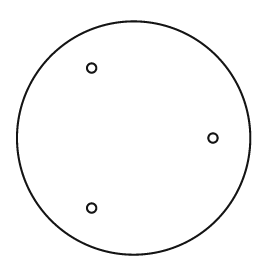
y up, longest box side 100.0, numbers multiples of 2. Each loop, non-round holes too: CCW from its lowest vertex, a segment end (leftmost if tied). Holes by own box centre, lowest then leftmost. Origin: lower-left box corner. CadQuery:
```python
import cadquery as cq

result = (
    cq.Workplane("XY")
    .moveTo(50.0, 50.0)
    .circle(50.0)
    .moveTo(32.0, 20.0)
    .circle(2.0)
    .moveTo(84.0, 50.0)
    .circle(2.0)
    .moveTo(32.0, 80.0)
    .circle(2.0)
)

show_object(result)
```